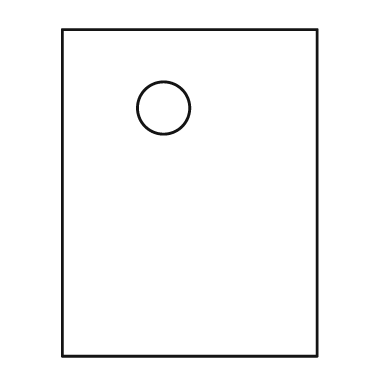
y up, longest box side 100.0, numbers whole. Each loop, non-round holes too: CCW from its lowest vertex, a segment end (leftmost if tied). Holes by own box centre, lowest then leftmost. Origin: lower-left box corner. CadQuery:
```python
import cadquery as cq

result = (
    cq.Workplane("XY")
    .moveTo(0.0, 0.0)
    .lineTo(78.0, 0.0)
    .lineTo(78.0, 100.0)
    .lineTo(0.0, 100.0)
    .close()
    .moveTo(31.0, 76.0)
    .circle(8.0)
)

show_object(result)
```